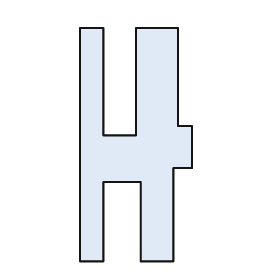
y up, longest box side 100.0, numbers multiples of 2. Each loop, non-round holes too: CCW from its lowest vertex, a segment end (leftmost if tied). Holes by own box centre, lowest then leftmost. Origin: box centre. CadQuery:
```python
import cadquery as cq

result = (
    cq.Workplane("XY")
    .moveTo(-24.0, -50.0)
    .lineTo(-14.0, -50.0)
    .lineTo(-14.0, -16.0)
    .lineTo(2.0, -16.0)
    .lineTo(2.0, -50.0)
    .lineTo(16.0, -50.0)
    .lineTo(16.0, -10.0)
    .lineTo(24.0, -10.0)
    .lineTo(24.0, 8.0)
    .lineTo(18.0, 8.0)
    .lineTo(18.0, 50.0)
    .lineTo(0.0, 50.0)
    .lineTo(0.0, 4.0)
    .lineTo(-14.0, 4.0)
    .lineTo(-14.0, 50.0)
    .lineTo(-24.0, 50.0)
    .close()
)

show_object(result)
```